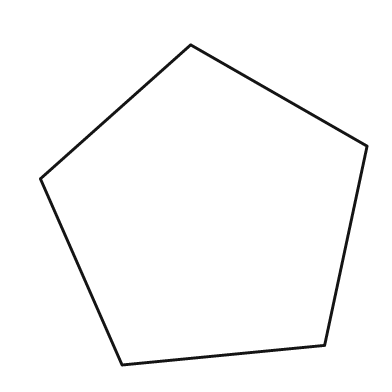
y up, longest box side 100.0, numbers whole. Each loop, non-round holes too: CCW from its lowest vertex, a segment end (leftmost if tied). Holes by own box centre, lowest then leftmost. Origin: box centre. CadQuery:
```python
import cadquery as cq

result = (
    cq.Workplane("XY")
    .moveTo(-25.0, -49.0)
    .lineTo(37.0, -43.0)
    .lineTo(50.0, 18.0)
    .lineTo(-4.0, 49.0)
    .lineTo(-50.0, 8.0)
    .close()
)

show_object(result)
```